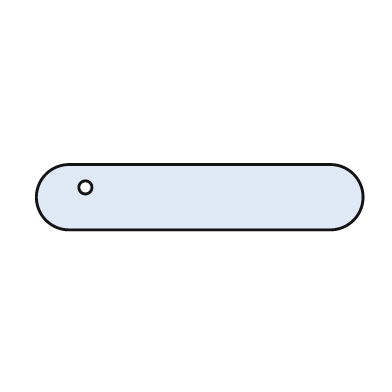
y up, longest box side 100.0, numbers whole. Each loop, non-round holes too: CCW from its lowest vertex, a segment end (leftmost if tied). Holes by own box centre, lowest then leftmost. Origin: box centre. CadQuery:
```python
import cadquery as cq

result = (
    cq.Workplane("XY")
    .moveTo(-40.0, -10.0)
    .lineTo(40.0, -10.0)
    .threePointArc((50.0, 0.0), (40.0, 10.0))
    .lineTo(-40.0, 10.0)
    .threePointArc((-50.0, 0.0), (-40.0, -10.0))
    .close()
    .moveTo(-35.0, 3.0)
    .circle(2.0)
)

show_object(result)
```